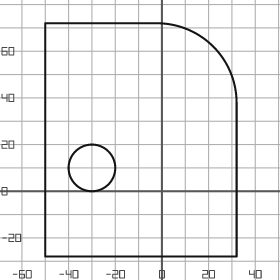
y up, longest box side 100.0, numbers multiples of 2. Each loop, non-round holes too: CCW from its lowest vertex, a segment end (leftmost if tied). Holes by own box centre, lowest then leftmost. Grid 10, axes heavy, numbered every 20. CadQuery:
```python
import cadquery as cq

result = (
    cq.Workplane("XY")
    .moveTo(-50.0, -28.0)
    .lineTo(32.0, -28.0)
    .lineTo(32.0, 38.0)
    .threePointArc((22.0, 62.0), (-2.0, 72.0))
    .lineTo(-50.0, 72.0)
    .close()
    .moveTo(-30.0, 10.0)
    .circle(10.0)
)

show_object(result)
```